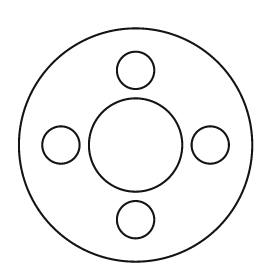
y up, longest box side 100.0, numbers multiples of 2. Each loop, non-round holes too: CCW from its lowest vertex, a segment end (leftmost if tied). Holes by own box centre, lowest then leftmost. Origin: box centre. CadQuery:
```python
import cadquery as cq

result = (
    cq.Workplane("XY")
    .moveTo(0.0, 0.0)
    .circle(50.0)
    .moveTo(0.0, -32.0)
    .circle(8.0)
    .moveTo(-32.0, 0.0)
    .circle(8.0)
    .moveTo(0.0, 0.0)
    .circle(20.0)
    .moveTo(32.0, 0.0)
    .circle(8.0)
    .moveTo(0.0, 32.0)
    .circle(8.0)
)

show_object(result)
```